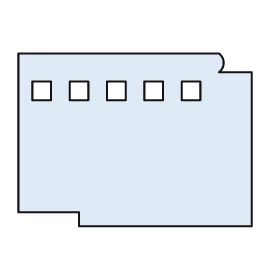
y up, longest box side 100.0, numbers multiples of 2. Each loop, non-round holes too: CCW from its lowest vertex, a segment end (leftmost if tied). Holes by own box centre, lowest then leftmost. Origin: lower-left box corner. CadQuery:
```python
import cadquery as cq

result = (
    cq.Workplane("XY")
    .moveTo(26.0, 0.0)
    .lineTo(100.0, 0.0)
    .lineTo(100.0, 66.0)
    .lineTo(86.0, 66.0)
    .threePointArc((88.0, 70.0), (86.0, 74.0))
    .lineTo(0.0, 74.0)
    .lineTo(0.0, 6.0)
    .lineTo(26.0, 6.0)
    .close()
    .moveTo(6.0, 54.0)
    .lineTo(14.0, 54.0)
    .lineTo(14.0, 62.0)
    .lineTo(6.0, 62.0)
    .close()
    .moveTo(22.0, 54.0)
    .lineTo(30.0, 54.0)
    .lineTo(30.0, 62.0)
    .lineTo(22.0, 62.0)
    .close()
    .moveTo(38.0, 54.0)
    .lineTo(46.0, 54.0)
    .lineTo(46.0, 62.0)
    .lineTo(38.0, 62.0)
    .close()
    .moveTo(54.0, 54.0)
    .lineTo(62.0, 54.0)
    .lineTo(62.0, 62.0)
    .lineTo(54.0, 62.0)
    .close()
    .moveTo(70.0, 54.0)
    .lineTo(78.0, 54.0)
    .lineTo(78.0, 62.0)
    .lineTo(70.0, 62.0)
    .close()
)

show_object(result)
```